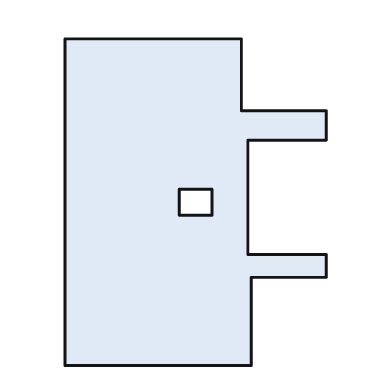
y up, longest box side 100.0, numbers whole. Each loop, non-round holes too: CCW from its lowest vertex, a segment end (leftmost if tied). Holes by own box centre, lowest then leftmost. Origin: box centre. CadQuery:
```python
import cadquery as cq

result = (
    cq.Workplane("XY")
    .moveTo(-40.0, -50.0)
    .lineTo(17.0, -50.0)
    .lineTo(17.0, -23.0)
    .lineTo(40.0, -23.0)
    .lineTo(40.0, -16.0)
    .lineTo(16.0, -16.0)
    .lineTo(16.0, 19.0)
    .lineTo(40.0, 19.0)
    .lineTo(40.0, 28.0)
    .lineTo(14.0, 28.0)
    .lineTo(14.0, 50.0)
    .lineTo(-40.0, 50.0)
    .close()
    .moveTo(-5.0, -4.0)
    .lineTo(5.0, -4.0)
    .lineTo(5.0, 4.0)
    .lineTo(-5.0, 4.0)
    .close()
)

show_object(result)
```